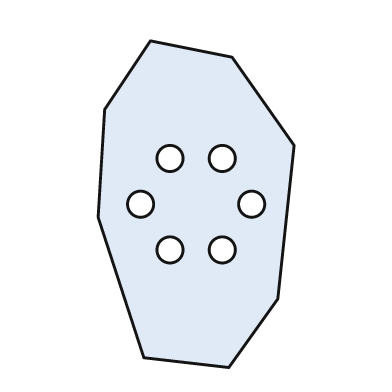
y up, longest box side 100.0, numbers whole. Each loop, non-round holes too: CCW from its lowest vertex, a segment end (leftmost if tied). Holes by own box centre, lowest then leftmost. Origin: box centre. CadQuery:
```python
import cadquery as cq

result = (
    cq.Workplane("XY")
    .moveTo(10.0, -50.0)
    .lineTo(25.0, -29.0)
    .lineTo(30.0, 18.0)
    .lineTo(11.0, 45.0)
    .lineTo(-14.0, 50.0)
    .lineTo(-28.0, 29.0)
    .lineTo(-30.0, -4.0)
    .lineTo(-16.0, -47.0)
    .close()
    .moveTo(-8.0, -14.0)
    .circle(4.0)
    .moveTo(8.0, -14.0)
    .circle(4.0)
    .moveTo(-17.0, 0.0)
    .circle(4.0)
    .moveTo(17.0, 0.0)
    .circle(4.0)
    .moveTo(-8.0, 14.0)
    .circle(4.0)
    .moveTo(8.0, 14.0)
    .circle(4.0)
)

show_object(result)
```